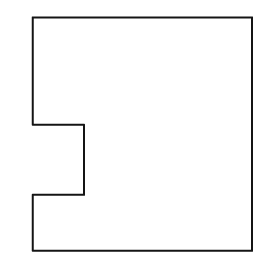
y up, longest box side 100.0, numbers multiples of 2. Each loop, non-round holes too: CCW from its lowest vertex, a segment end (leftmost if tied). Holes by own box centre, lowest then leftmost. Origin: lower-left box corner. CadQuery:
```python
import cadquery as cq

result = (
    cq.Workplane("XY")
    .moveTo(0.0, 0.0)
    .lineTo(94.0, 0.0)
    .lineTo(94.0, 100.0)
    .lineTo(0.0, 100.0)
    .lineTo(0.0, 54.0)
    .lineTo(22.0, 54.0)
    .lineTo(22.0, 24.0)
    .lineTo(0.0, 24.0)
    .close()
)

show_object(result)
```